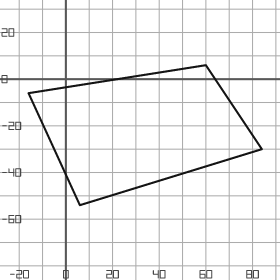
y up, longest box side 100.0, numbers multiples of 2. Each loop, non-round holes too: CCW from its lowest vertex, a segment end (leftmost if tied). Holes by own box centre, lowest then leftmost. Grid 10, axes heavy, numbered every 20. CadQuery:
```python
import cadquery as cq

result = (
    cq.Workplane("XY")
    .moveTo(6.0, -54.0)
    .lineTo(84.0, -30.0)
    .lineTo(60.0, 6.0)
    .lineTo(-16.0, -6.0)
    .close()
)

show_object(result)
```